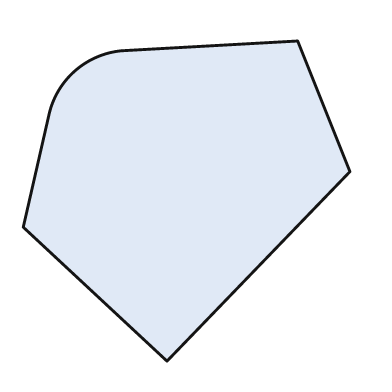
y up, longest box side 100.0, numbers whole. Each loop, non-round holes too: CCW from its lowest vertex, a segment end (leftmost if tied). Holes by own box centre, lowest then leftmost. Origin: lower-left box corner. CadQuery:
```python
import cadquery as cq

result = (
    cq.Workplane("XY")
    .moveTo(44.0, 0.0)
    .lineTo(100.0, 58.0)
    .lineTo(84.0, 98.0)
    .lineTo(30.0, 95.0)
    .threePointArc((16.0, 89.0), (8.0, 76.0))
    .lineTo(0.0, 41.0)
    .close()
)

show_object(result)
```